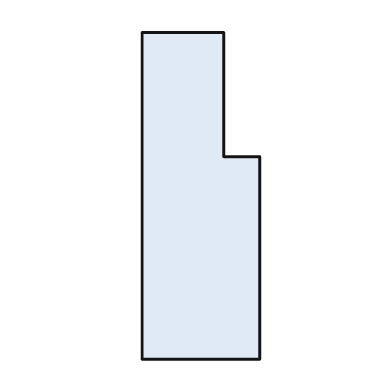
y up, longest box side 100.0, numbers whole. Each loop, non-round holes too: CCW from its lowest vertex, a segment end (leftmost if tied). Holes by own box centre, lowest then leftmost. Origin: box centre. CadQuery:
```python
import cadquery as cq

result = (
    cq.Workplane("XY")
    .moveTo(-18.0, -50.0)
    .lineTo(18.0, -50.0)
    .lineTo(18.0, 12.0)
    .lineTo(7.0, 12.0)
    .lineTo(7.0, 50.0)
    .lineTo(-18.0, 50.0)
    .close()
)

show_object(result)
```